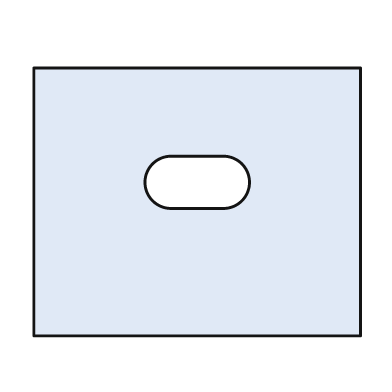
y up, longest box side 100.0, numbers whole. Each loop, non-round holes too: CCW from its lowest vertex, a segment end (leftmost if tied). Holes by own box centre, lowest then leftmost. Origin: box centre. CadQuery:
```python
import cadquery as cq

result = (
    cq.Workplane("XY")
    .moveTo(-50.0, -41.0)
    .lineTo(50.0, -41.0)
    .lineTo(50.0, 41.0)
    .lineTo(-50.0, 41.0)
    .close()
    .moveTo(-8.0, -2.0)
    .lineTo(8.0, -2.0)
    .threePointArc((16.0, 6.0), (8.0, 14.0))
    .lineTo(-8.0, 14.0)
    .threePointArc((-16.0, 6.0), (-8.0, -2.0))
    .close()
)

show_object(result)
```